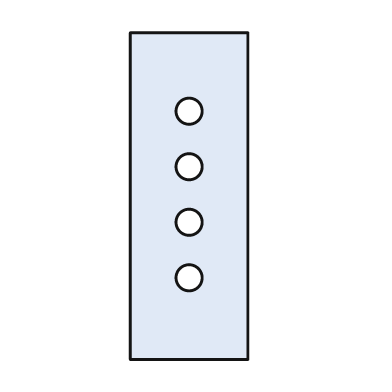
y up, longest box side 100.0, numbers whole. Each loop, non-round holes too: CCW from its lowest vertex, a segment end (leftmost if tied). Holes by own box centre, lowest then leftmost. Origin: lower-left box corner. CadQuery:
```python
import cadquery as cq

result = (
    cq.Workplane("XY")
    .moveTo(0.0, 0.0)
    .lineTo(36.0, 0.0)
    .lineTo(36.0, 100.0)
    .lineTo(0.0, 100.0)
    .close()
    .moveTo(18.0, 25.0)
    .circle(4.0)
    .moveTo(18.0, 42.0)
    .circle(4.0)
    .moveTo(18.0, 59.0)
    .circle(4.0)
    .moveTo(18.0, 76.0)
    .circle(4.0)
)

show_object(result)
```